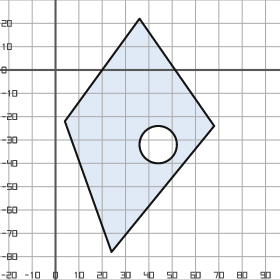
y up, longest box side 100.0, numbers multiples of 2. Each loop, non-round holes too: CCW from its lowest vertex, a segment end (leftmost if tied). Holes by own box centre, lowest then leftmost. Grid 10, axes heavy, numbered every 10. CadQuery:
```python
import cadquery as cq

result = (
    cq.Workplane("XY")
    .moveTo(24.0, -78.0)
    .lineTo(68.0, -24.0)
    .lineTo(36.0, 22.0)
    .lineTo(4.0, -22.0)
    .close()
    .moveTo(44.0, -32.0)
    .circle(8.0)
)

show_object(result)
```